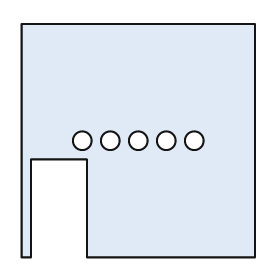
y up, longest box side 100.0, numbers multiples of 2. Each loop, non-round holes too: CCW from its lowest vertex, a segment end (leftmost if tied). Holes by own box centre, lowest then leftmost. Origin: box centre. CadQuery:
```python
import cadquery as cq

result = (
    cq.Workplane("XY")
    .moveTo(-50.0, -50.0)
    .lineTo(-46.0, -50.0)
    .lineTo(-46.0, -8.0)
    .lineTo(-22.0, -8.0)
    .lineTo(-22.0, -50.0)
    .lineTo(50.0, -50.0)
    .lineTo(50.0, 50.0)
    .lineTo(-50.0, 50.0)
    .close()
    .moveTo(-24.0, 0.0)
    .circle(4.0)
    .moveTo(-12.0, 0.0)
    .circle(4.0)
    .moveTo(0.0, 0.0)
    .circle(4.0)
    .moveTo(12.0, 0.0)
    .circle(4.0)
    .moveTo(24.0, 0.0)
    .circle(4.0)
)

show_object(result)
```